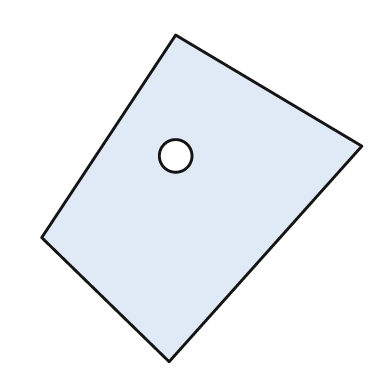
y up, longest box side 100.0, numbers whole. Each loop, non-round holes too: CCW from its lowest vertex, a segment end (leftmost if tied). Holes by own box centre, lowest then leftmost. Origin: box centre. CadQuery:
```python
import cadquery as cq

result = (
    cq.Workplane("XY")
    .moveTo(-10.0, -50.0)
    .lineTo(49.0, 16.0)
    .lineTo(-8.0, 50.0)
    .lineTo(-49.0, -12.0)
    .close()
    .moveTo(-8.0, 13.0)
    .circle(5.0)
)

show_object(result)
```